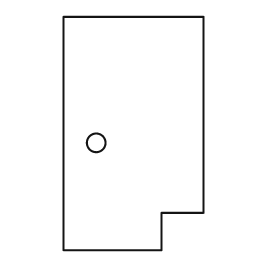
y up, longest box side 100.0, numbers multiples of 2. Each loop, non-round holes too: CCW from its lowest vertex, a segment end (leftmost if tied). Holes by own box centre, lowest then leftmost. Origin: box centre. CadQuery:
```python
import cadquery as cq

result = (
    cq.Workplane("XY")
    .moveTo(-30.0, -50.0)
    .lineTo(12.0, -50.0)
    .lineTo(12.0, -34.0)
    .lineTo(30.0, -34.0)
    .lineTo(30.0, 50.0)
    .lineTo(-30.0, 50.0)
    .close()
    .moveTo(-16.0, -4.0)
    .circle(4.0)
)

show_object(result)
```